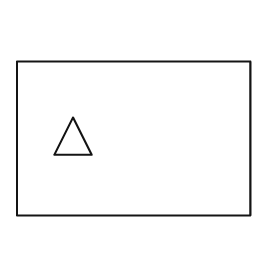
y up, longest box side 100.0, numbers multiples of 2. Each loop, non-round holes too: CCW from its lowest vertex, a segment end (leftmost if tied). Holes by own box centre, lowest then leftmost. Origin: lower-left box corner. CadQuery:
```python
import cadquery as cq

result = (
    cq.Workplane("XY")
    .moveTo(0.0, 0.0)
    .lineTo(100.0, 0.0)
    .lineTo(100.0, 66.0)
    .lineTo(0.0, 66.0)
    .close()
    .moveTo(16.0, 26.0)
    .lineTo(32.0, 26.0)
    .lineTo(24.0, 42.0)
    .close()
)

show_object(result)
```